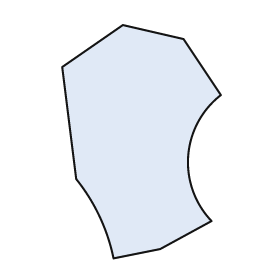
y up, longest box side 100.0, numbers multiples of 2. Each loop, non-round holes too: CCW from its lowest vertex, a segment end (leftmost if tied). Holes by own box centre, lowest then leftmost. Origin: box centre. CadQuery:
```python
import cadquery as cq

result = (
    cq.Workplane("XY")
    .moveTo(-12.0, -50.0)
    .lineTo(8.0, -46.0)
    .lineTo(30.0, -34.0)
    .threePointArc((20.0, -6.0), (34.0, 20.0))
    .lineTo(18.0, 44.0)
    .lineTo(-8.0, 50.0)
    .lineTo(-34.0, 32.0)
    .lineTo(-28.0, -16.0)
    .threePointArc((-18.0, -32.0), (-12.0, -50.0))
    .close()
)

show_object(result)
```